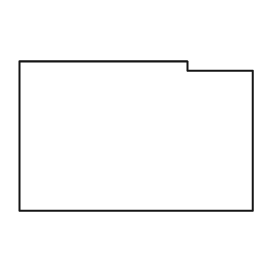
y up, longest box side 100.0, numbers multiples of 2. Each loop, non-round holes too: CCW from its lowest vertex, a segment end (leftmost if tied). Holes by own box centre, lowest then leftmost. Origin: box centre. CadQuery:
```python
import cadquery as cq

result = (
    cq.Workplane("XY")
    .moveTo(-50.0, -32.0)
    .lineTo(50.0, -32.0)
    .lineTo(50.0, 28.0)
    .lineTo(22.0, 28.0)
    .lineTo(22.0, 32.0)
    .lineTo(-50.0, 32.0)
    .close()
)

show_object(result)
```